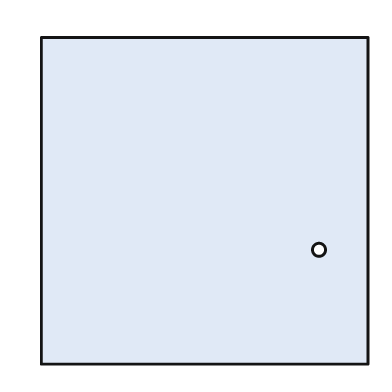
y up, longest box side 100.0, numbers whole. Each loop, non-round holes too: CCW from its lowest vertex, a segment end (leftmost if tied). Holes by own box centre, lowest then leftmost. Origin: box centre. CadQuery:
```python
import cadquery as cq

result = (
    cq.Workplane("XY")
    .moveTo(-50.0, -50.0)
    .lineTo(50.0, -50.0)
    .lineTo(50.0, 50.0)
    .lineTo(-50.0, 50.0)
    .close()
    .moveTo(35.0, -15.0)
    .circle(2.0)
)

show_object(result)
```